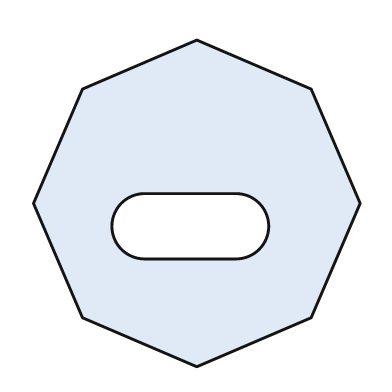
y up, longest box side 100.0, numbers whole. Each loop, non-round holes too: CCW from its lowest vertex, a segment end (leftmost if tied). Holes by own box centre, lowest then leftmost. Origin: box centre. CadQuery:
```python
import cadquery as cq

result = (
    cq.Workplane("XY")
    .moveTo(0.0, -50.0)
    .lineTo(35.0, -35.0)
    .lineTo(50.0, 0.0)
    .lineTo(35.0, 35.0)
    .lineTo(0.0, 50.0)
    .lineTo(-35.0, 35.0)
    .lineTo(-50.0, 0.0)
    .lineTo(-35.0, -35.0)
    .close()
    .moveTo(-16.0, -17.0)
    .lineTo(12.0, -17.0)
    .threePointArc((22.0, -7.0), (12.0, 3.0))
    .lineTo(-16.0, 3.0)
    .threePointArc((-26.0, -7.0), (-16.0, -17.0))
    .close()
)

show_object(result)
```